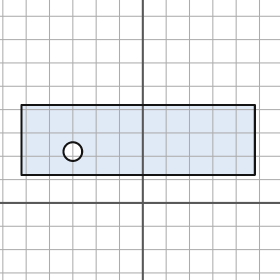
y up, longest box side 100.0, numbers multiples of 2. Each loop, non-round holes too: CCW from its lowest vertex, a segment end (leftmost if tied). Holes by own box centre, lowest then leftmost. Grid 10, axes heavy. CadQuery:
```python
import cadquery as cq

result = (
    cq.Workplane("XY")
    .moveTo(-52.0, 12.0)
    .lineTo(48.0, 12.0)
    .lineTo(48.0, 42.0)
    .lineTo(-52.0, 42.0)
    .close()
    .moveTo(-30.0, 22.0)
    .circle(4.0)
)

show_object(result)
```